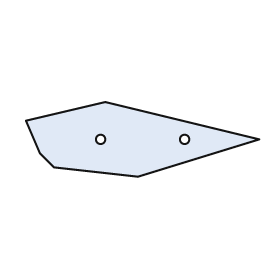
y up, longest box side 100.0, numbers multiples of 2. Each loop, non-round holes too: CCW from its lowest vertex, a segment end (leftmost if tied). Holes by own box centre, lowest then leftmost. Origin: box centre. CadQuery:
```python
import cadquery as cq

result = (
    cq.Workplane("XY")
    .moveTo(-2.0, -16.0)
    .lineTo(50.0, 0.0)
    .lineTo(-16.0, 16.0)
    .lineTo(-50.0, 8.0)
    .lineTo(-44.0, -6.0)
    .lineTo(-38.0, -12.0)
    .close()
    .moveTo(-18.0, 0.0)
    .circle(2.0)
    .moveTo(18.0, 0.0)
    .circle(2.0)
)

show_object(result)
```